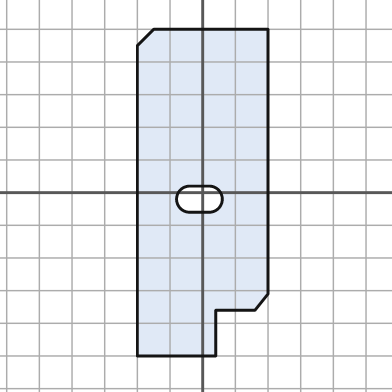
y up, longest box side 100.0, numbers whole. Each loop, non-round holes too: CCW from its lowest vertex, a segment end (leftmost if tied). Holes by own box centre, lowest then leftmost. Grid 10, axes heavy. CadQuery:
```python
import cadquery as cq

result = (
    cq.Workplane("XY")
    .moveTo(-20.0, -50.0)
    .lineTo(4.0, -50.0)
    .lineTo(4.0, -36.0)
    .lineTo(16.0, -36.0)
    .lineTo(20.0, -31.0)
    .lineTo(20.0, 50.0)
    .lineTo(-15.0, 50.0)
    .lineTo(-20.0, 45.0)
    .close()
    .moveTo(-4.0, -6.0)
    .lineTo(2.0, -6.0)
    .threePointArc((6.0, -2.0), (2.0, 2.0))
    .lineTo(-4.0, 2.0)
    .threePointArc((-8.0, -2.0), (-4.0, -6.0))
    .close()
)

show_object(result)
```